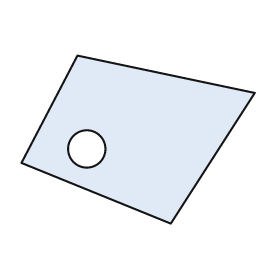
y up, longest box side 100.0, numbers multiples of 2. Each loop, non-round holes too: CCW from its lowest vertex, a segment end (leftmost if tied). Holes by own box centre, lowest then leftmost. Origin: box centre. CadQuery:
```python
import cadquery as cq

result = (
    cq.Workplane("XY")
    .moveTo(14.0, -36.0)
    .lineTo(50.0, 20.0)
    .lineTo(-26.0, 36.0)
    .lineTo(-50.0, -10.0)
    .close()
    .moveTo(-22.0, -4.0)
    .circle(8.0)
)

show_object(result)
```